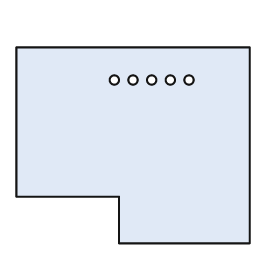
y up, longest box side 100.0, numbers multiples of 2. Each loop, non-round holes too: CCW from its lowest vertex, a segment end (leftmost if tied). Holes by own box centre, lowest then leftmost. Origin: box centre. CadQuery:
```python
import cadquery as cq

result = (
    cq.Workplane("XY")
    .moveTo(-6.0, -42.0)
    .lineTo(50.0, -42.0)
    .lineTo(50.0, 42.0)
    .lineTo(-50.0, 42.0)
    .lineTo(-50.0, -22.0)
    .lineTo(-6.0, -22.0)
    .close()
    .moveTo(-8.0, 28.0)
    .circle(2.0)
    .moveTo(0.0, 28.0)
    .circle(2.0)
    .moveTo(8.0, 28.0)
    .circle(2.0)
    .moveTo(16.0, 28.0)
    .circle(2.0)
    .moveTo(24.0, 28.0)
    .circle(2.0)
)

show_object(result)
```